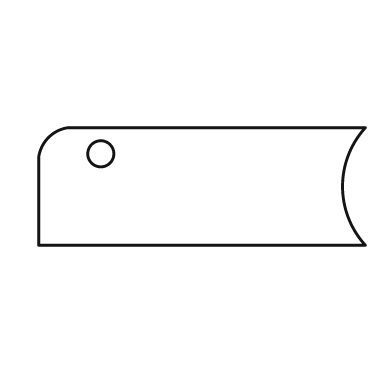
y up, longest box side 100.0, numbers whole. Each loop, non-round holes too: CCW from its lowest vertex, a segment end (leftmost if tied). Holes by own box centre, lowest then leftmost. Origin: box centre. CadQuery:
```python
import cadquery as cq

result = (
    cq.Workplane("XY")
    .moveTo(-50.0, -18.0)
    .lineTo(50.0, -18.0)
    .threePointArc((43.0, 0.0), (50.0, 18.0))
    .lineTo(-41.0, 18.0)
    .threePointArc((-47.0, 15.0), (-50.0, 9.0))
    .close()
    .moveTo(-31.0, 10.0)
    .circle(4.0)
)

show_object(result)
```